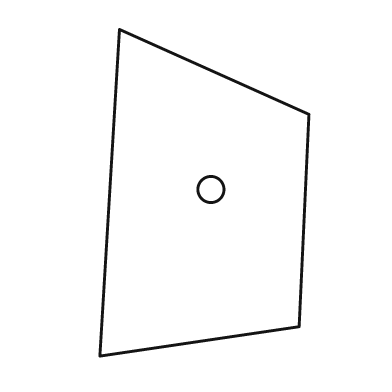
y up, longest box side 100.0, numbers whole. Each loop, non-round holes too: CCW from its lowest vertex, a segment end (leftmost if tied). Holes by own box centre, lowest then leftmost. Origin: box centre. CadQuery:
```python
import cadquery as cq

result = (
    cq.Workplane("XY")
    .moveTo(-32.0, -50.0)
    .lineTo(29.0, -41.0)
    .lineTo(32.0, 24.0)
    .lineTo(-26.0, 50.0)
    .close()
    .moveTo(2.0, 1.0)
    .circle(4.0)
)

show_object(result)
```